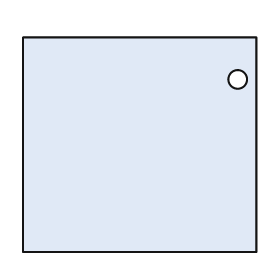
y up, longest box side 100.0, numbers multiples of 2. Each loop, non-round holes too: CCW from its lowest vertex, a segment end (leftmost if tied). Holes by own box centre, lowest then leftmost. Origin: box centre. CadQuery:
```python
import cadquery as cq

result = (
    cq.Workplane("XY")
    .moveTo(-50.0, -46.0)
    .lineTo(50.0, -46.0)
    .lineTo(50.0, 46.0)
    .lineTo(-50.0, 46.0)
    .close()
    .moveTo(42.0, 28.0)
    .circle(4.0)
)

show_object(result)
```